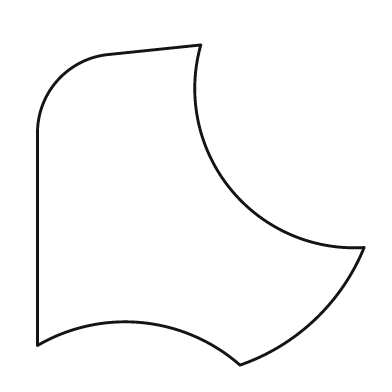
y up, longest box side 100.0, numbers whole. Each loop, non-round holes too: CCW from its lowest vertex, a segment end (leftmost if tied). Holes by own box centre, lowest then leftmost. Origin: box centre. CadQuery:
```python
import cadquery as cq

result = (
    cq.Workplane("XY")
    .moveTo(12.0, -49.0)
    .threePointArc((35.0, -35.0), (50.0, -13.0))
    .threePointArc((9.0, 5.0), (0.0, 49.0))
    .lineTo(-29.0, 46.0)
    .threePointArc((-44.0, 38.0), (-50.0, 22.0))
    .lineTo(-50.0, -43.0)
    .threePointArc((-18.0, -36.0), (12.0, -49.0))
    .close()
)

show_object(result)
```